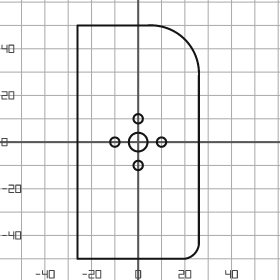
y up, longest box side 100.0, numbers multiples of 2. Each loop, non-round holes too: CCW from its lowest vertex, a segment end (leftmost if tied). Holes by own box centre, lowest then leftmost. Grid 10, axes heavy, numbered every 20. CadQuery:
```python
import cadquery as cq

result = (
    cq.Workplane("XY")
    .moveTo(-26.0, -50.0)
    .lineTo(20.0, -50.0)
    .threePointArc((24.0, -48.0), (26.0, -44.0))
    .lineTo(26.0, 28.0)
    .threePointArc((20.0, 44.0), (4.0, 50.0))
    .lineTo(-26.0, 50.0)
    .close()
    .moveTo(0.0, -10.0)
    .circle(2.0)
    .moveTo(-10.0, 0.0)
    .circle(2.0)
    .moveTo(0.0, 0.0)
    .circle(4.0)
    .moveTo(10.0, 0.0)
    .circle(2.0)
    .moveTo(0.0, 10.0)
    .circle(2.0)
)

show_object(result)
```